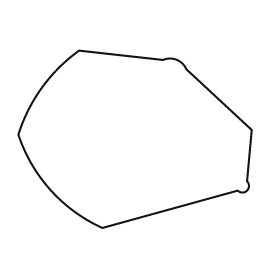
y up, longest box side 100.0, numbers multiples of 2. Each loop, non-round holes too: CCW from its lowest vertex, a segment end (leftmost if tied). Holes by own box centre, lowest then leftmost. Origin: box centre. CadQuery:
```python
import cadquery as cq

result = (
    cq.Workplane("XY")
    .moveTo(-14.0, -38.0)
    .lineTo(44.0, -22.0)
    .threePointArc((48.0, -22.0), (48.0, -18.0))
    .lineTo(50.0, 4.0)
    .lineTo(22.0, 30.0)
    .threePointArc((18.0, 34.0), (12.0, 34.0))
    .lineTo(-24.0, 38.0)
    .threePointArc((-40.0, 22.0), (-50.0, 2.0))
    .threePointArc((-36.0, -22.0), (-14.0, -38.0))
    .close()
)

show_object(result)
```